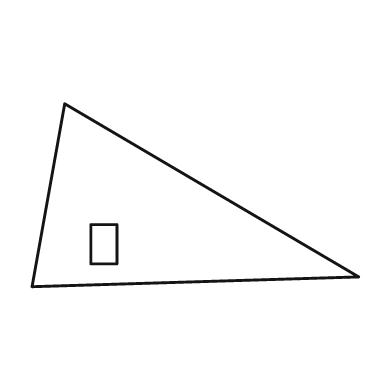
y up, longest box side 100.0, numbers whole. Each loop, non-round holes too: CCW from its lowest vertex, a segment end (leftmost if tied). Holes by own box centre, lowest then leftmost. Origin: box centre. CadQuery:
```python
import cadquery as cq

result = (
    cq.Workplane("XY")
    .moveTo(-50.0, -28.0)
    .lineTo(50.0, -25.0)
    .lineTo(-40.0, 28.0)
    .close()
    .moveTo(-32.0, -21.0)
    .lineTo(-24.0, -21.0)
    .lineTo(-24.0, -9.0)
    .lineTo(-32.0, -9.0)
    .close()
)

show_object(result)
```